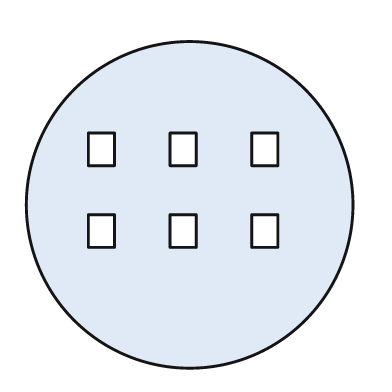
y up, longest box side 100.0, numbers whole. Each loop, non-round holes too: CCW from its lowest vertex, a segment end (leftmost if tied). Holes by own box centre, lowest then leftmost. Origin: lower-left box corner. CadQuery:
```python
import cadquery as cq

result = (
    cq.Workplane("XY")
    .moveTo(50.0, 50.0)
    .circle(50.0)
    .moveTo(19.0, 37.0)
    .lineTo(27.0, 37.0)
    .lineTo(27.0, 47.0)
    .lineTo(19.0, 47.0)
    .close()
    .moveTo(44.0, 37.0)
    .lineTo(52.0, 37.0)
    .lineTo(52.0, 47.0)
    .lineTo(44.0, 47.0)
    .close()
    .moveTo(69.0, 37.0)
    .lineTo(77.0, 37.0)
    .lineTo(77.0, 47.0)
    .lineTo(69.0, 47.0)
    .close()
    .moveTo(19.0, 62.0)
    .lineTo(27.0, 62.0)
    .lineTo(27.0, 72.0)
    .lineTo(19.0, 72.0)
    .close()
    .moveTo(44.0, 62.0)
    .lineTo(52.0, 62.0)
    .lineTo(52.0, 72.0)
    .lineTo(44.0, 72.0)
    .close()
    .moveTo(69.0, 62.0)
    .lineTo(77.0, 62.0)
    .lineTo(77.0, 72.0)
    .lineTo(69.0, 72.0)
    .close()
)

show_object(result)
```